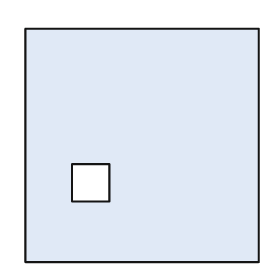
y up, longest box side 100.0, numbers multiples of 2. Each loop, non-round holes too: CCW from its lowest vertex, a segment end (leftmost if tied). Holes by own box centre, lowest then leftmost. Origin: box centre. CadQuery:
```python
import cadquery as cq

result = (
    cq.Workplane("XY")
    .moveTo(-50.0, -50.0)
    .lineTo(50.0, -50.0)
    .lineTo(50.0, 50.0)
    .lineTo(-50.0, 50.0)
    .close()
    .moveTo(-30.0, -24.0)
    .lineTo(-14.0, -24.0)
    .lineTo(-14.0, -8.0)
    .lineTo(-30.0, -8.0)
    .close()
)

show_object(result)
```